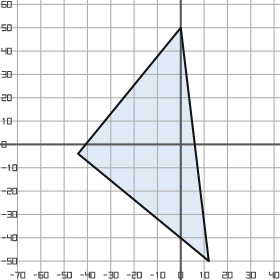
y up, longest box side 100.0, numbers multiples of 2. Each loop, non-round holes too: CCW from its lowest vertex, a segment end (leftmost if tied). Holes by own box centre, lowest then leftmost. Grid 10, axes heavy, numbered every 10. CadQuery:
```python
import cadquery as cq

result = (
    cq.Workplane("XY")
    .moveTo(12.0, -50.0)
    .lineTo(0.0, 50.0)
    .lineTo(-44.0, -4.0)
    .close()
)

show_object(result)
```